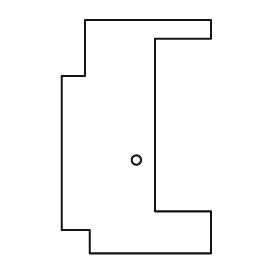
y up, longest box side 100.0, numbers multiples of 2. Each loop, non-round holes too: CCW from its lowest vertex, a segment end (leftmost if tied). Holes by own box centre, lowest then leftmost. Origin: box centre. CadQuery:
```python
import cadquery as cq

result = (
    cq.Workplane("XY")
    .moveTo(-20.0, -50.0)
    .lineTo(32.0, -50.0)
    .lineTo(32.0, -32.0)
    .lineTo(8.0, -32.0)
    .lineTo(8.0, 42.0)
    .lineTo(32.0, 42.0)
    .lineTo(32.0, 50.0)
    .lineTo(-22.0, 50.0)
    .lineTo(-22.0, 26.0)
    .lineTo(-32.0, 26.0)
    .lineTo(-32.0, -40.0)
    .lineTo(-20.0, -40.0)
    .close()
    .moveTo(0.0, -10.0)
    .circle(2.0)
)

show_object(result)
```